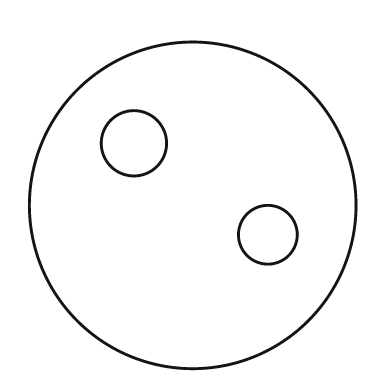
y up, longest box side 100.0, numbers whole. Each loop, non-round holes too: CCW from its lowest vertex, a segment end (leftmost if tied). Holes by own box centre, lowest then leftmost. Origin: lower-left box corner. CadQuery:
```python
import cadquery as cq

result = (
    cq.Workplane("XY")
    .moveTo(50.0, 50.0)
    .circle(50.0)
    .moveTo(73.0, 41.0)
    .circle(9.0)
    .moveTo(32.0, 69.0)
    .circle(10.0)
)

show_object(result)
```